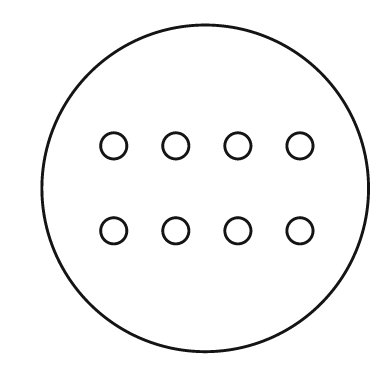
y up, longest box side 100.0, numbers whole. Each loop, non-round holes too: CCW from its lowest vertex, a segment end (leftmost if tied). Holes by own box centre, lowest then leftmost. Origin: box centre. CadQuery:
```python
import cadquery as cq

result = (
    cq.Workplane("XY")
    .moveTo(0.0, 0.0)
    .circle(50.0)
    .moveTo(-28.0, -13.0)
    .circle(4.0)
    .moveTo(-9.0, -13.0)
    .circle(4.0)
    .moveTo(10.0, -13.0)
    .circle(4.0)
    .moveTo(29.0, -13.0)
    .circle(4.0)
    .moveTo(-28.0, 13.0)
    .circle(4.0)
    .moveTo(-9.0, 13.0)
    .circle(4.0)
    .moveTo(10.0, 13.0)
    .circle(4.0)
    .moveTo(29.0, 13.0)
    .circle(4.0)
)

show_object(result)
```